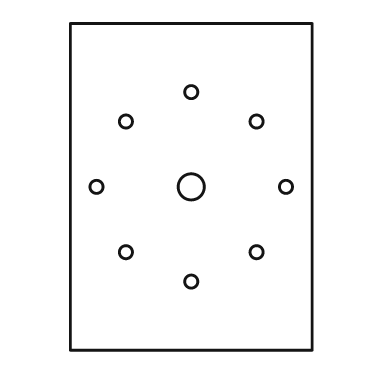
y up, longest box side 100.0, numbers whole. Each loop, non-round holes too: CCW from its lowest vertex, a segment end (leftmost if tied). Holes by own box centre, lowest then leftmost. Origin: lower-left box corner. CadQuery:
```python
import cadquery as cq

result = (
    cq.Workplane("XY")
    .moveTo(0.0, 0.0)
    .lineTo(74.0, 0.0)
    .lineTo(74.0, 100.0)
    .lineTo(0.0, 100.0)
    .close()
    .moveTo(37.0, 21.0)
    .circle(2.0)
    .moveTo(17.0, 30.0)
    .circle(2.0)
    .moveTo(57.0, 30.0)
    .circle(2.0)
    .moveTo(8.0, 50.0)
    .circle(2.0)
    .moveTo(37.0, 50.0)
    .circle(4.0)
    .moveTo(66.0, 50.0)
    .circle(2.0)
    .moveTo(17.0, 70.0)
    .circle(2.0)
    .moveTo(57.0, 70.0)
    .circle(2.0)
    .moveTo(37.0, 79.0)
    .circle(2.0)
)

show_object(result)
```